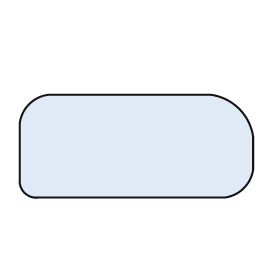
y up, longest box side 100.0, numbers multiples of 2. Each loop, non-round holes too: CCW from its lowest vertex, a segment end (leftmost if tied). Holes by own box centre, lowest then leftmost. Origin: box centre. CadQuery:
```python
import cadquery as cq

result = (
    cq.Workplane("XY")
    .moveTo(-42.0, -22.0)
    .lineTo(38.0, -22.0)
    .threePointArc((46.0, -18.0), (50.0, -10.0))
    .lineTo(50.0, 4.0)
    .threePointArc((44.0, 16.0), (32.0, 22.0))
    .lineTo(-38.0, 22.0)
    .threePointArc((-46.0, 18.0), (-50.0, 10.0))
    .lineTo(-50.0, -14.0)
    .threePointArc((-48.0, -20.0), (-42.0, -22.0))
    .close()
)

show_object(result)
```